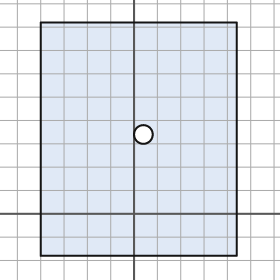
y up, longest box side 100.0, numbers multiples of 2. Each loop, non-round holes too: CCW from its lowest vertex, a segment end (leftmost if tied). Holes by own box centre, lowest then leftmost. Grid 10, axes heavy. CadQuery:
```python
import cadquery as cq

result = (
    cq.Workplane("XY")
    .moveTo(-40.0, -18.0)
    .lineTo(44.0, -18.0)
    .lineTo(44.0, 82.0)
    .lineTo(-40.0, 82.0)
    .close()
    .moveTo(4.0, 34.0)
    .circle(4.0)
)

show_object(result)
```